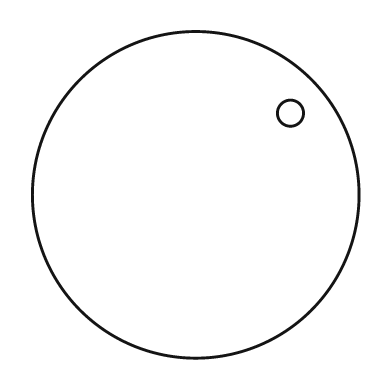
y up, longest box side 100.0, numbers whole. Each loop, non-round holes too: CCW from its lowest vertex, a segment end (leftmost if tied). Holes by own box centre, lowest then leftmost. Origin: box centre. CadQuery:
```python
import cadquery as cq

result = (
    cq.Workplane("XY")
    .moveTo(0.0, 0.0)
    .circle(50.0)
    .moveTo(29.0, 25.0)
    .circle(4.0)
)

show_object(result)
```